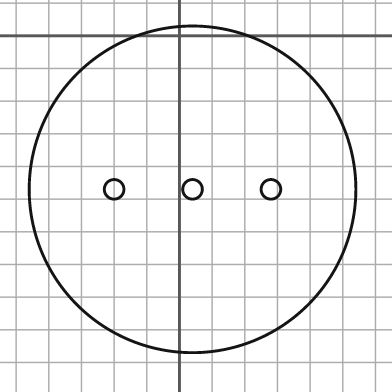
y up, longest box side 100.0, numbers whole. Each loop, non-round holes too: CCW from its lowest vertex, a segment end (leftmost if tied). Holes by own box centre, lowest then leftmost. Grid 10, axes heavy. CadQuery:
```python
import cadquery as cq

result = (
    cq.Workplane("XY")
    .moveTo(4.0, -47.0)
    .circle(50.0)
    .moveTo(-20.0, -47.0)
    .circle(3.0)
    .moveTo(4.0, -47.0)
    .circle(3.0)
    .moveTo(28.0, -47.0)
    .circle(3.0)
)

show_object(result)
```